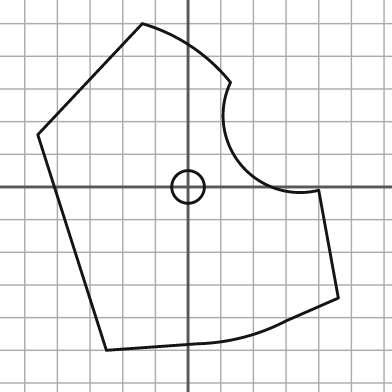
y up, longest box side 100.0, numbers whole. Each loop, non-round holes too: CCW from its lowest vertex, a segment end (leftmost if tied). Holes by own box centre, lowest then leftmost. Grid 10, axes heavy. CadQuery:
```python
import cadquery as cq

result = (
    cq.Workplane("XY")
    .moveTo(-25.0, -50.0)
    .lineTo(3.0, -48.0)
    .threePointArc((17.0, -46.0), (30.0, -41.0))
    .lineTo(46.0, -34.0)
    .lineTo(40.0, -1.0)
    .threePointArc((16.0, 7.0), (13.0, 32.0))
    .threePointArc((1.0, 43.0), (-14.0, 50.0))
    .lineTo(-46.0, 16.0)
    .close()
    .moveTo(0.0, 0.0)
    .circle(5.0)
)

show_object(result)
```